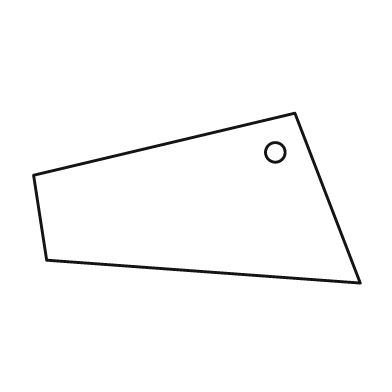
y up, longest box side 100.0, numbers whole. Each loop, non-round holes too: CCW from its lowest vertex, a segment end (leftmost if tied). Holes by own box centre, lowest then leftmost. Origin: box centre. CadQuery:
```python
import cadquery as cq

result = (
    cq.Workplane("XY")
    .moveTo(50.0, -26.0)
    .lineTo(30.0, 26.0)
    .lineTo(-50.0, 7.0)
    .lineTo(-46.0, -19.0)
    .close()
    .moveTo(24.0, 14.0)
    .circle(3.0)
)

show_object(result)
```